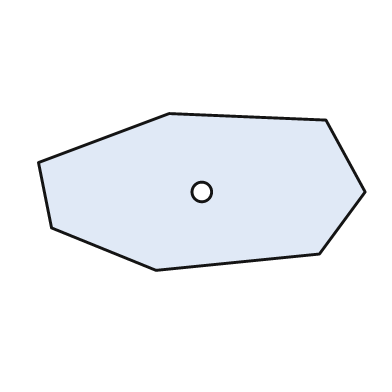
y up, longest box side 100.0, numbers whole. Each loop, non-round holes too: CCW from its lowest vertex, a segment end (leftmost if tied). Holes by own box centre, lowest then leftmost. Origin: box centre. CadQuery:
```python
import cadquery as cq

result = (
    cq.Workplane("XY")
    .moveTo(-14.0, -24.0)
    .lineTo(36.0, -19.0)
    .lineTo(50.0, 0.0)
    .lineTo(38.0, 22.0)
    .lineTo(-10.0, 24.0)
    .lineTo(-50.0, 9.0)
    .lineTo(-46.0, -11.0)
    .close()
    .moveTo(0.0, 0.0)
    .circle(3.0)
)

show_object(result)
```